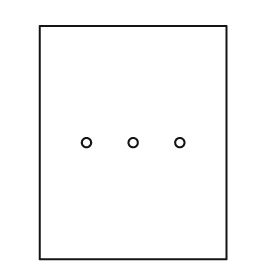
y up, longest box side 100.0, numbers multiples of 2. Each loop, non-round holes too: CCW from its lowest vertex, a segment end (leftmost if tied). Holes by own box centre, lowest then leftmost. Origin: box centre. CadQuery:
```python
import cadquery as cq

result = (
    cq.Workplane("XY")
    .moveTo(-40.0, -50.0)
    .lineTo(40.0, -50.0)
    .lineTo(40.0, 50.0)
    .lineTo(-40.0, 50.0)
    .close()
    .moveTo(-20.0, 0.0)
    .circle(2.0)
    .moveTo(0.0, 0.0)
    .circle(2.0)
    .moveTo(20.0, 0.0)
    .circle(2.0)
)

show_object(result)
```